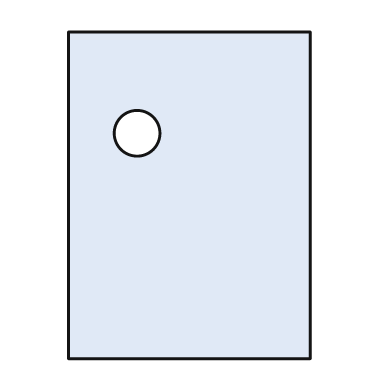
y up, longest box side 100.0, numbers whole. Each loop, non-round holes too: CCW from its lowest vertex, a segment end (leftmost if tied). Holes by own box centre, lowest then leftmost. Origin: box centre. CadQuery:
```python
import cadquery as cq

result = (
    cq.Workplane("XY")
    .moveTo(-37.0, -50.0)
    .lineTo(37.0, -50.0)
    .lineTo(37.0, 50.0)
    .lineTo(-37.0, 50.0)
    .close()
    .moveTo(-16.0, 19.0)
    .circle(7.0)
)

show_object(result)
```